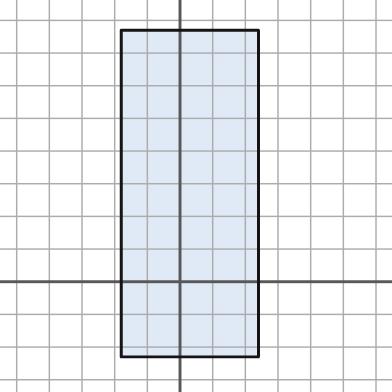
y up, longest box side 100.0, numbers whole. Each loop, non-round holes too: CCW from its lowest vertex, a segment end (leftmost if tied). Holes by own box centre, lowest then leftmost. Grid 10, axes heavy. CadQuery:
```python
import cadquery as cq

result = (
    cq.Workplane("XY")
    .moveTo(-18.0, -23.0)
    .lineTo(24.0, -23.0)
    .lineTo(24.0, 77.0)
    .lineTo(-18.0, 77.0)
    .close()
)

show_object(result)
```